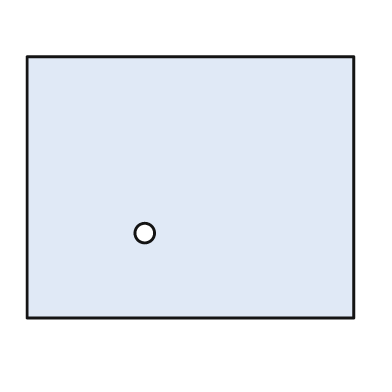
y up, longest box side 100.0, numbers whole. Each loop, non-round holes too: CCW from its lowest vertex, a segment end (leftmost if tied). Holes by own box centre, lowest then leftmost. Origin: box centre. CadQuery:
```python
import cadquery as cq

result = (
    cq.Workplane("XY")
    .moveTo(-50.0, -40.0)
    .lineTo(50.0, -40.0)
    .lineTo(50.0, 40.0)
    .lineTo(-50.0, 40.0)
    .close()
    .moveTo(-14.0, -14.0)
    .circle(3.0)
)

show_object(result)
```